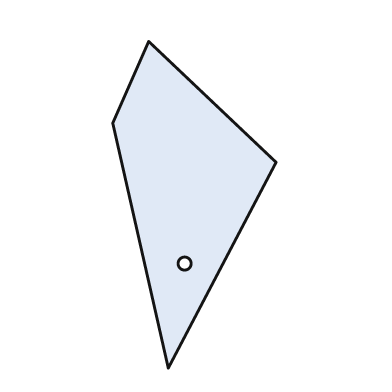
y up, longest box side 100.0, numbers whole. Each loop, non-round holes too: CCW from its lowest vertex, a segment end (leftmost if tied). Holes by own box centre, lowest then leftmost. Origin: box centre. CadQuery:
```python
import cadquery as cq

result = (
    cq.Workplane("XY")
    .moveTo(-8.0, -50.0)
    .lineTo(25.0, 13.0)
    .lineTo(-14.0, 50.0)
    .lineTo(-25.0, 25.0)
    .close()
    .moveTo(-3.0, -18.0)
    .circle(2.0)
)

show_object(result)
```